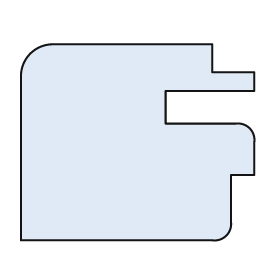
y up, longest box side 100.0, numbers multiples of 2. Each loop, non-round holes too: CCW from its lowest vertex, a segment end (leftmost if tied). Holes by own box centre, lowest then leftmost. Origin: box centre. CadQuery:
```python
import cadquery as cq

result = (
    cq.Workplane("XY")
    .moveTo(-50.0, -42.0)
    .lineTo(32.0, -42.0)
    .threePointArc((38.0, -40.0), (40.0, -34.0))
    .lineTo(40.0, -14.0)
    .lineTo(50.0, -14.0)
    .lineTo(50.0, 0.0)
    .threePointArc((48.0, 6.0), (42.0, 8.0))
    .lineTo(12.0, 8.0)
    .lineTo(12.0, 22.0)
    .lineTo(50.0, 22.0)
    .lineTo(50.0, 30.0)
    .lineTo(32.0, 30.0)
    .lineTo(32.0, 42.0)
    .lineTo(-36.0, 42.0)
    .threePointArc((-46.0, 38.0), (-50.0, 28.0))
    .close()
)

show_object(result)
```